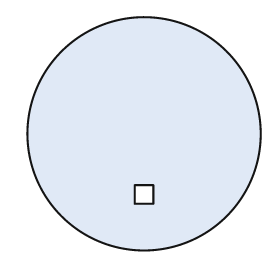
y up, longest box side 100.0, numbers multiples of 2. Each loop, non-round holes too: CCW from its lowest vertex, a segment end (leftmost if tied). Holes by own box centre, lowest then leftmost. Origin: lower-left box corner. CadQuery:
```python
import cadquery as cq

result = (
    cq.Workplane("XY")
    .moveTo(50.0, 50.0)
    .circle(50.0)
    .moveTo(46.0, 20.0)
    .lineTo(54.0, 20.0)
    .lineTo(54.0, 28.0)
    .lineTo(46.0, 28.0)
    .close()
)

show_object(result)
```